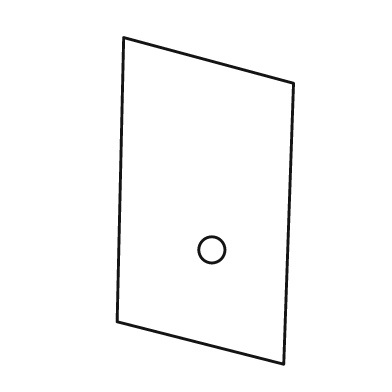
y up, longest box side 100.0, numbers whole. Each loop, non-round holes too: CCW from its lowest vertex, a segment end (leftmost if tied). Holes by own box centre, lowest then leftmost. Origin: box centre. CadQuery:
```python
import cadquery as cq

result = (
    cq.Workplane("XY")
    .moveTo(24.0, -50.0)
    .lineTo(27.0, 36.0)
    .lineTo(-25.0, 50.0)
    .lineTo(-27.0, -37.0)
    .close()
    .moveTo(2.0, -15.0)
    .circle(4.0)
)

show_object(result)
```